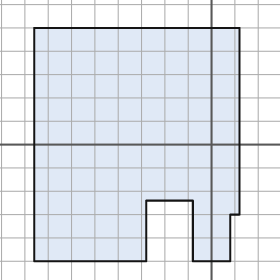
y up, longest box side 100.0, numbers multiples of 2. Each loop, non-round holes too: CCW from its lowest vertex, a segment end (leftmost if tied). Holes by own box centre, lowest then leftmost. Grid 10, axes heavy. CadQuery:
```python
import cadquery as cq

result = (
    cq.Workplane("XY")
    .moveTo(-76.0, -50.0)
    .lineTo(-28.0, -50.0)
    .lineTo(-28.0, -24.0)
    .lineTo(-8.0, -24.0)
    .lineTo(-8.0, -50.0)
    .lineTo(8.0, -50.0)
    .lineTo(8.0, -30.0)
    .lineTo(12.0, -30.0)
    .lineTo(12.0, 50.0)
    .lineTo(-76.0, 50.0)
    .close()
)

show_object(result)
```